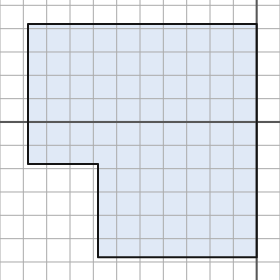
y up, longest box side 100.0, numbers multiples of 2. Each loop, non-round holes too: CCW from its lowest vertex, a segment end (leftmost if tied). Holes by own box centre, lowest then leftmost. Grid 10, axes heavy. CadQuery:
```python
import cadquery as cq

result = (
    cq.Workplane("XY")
    .moveTo(-68.0, -58.0)
    .lineTo(0.0, -58.0)
    .lineTo(0.0, 42.0)
    .lineTo(-98.0, 42.0)
    .lineTo(-98.0, -18.0)
    .lineTo(-68.0, -18.0)
    .close()
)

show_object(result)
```